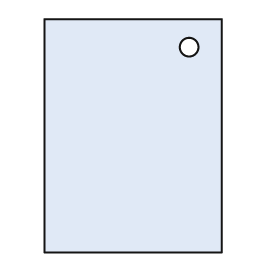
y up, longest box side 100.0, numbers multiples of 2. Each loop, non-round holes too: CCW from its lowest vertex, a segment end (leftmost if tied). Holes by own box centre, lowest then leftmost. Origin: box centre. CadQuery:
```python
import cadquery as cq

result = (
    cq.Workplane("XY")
    .moveTo(-38.0, -50.0)
    .lineTo(38.0, -50.0)
    .lineTo(38.0, 50.0)
    .lineTo(-38.0, 50.0)
    .close()
    .moveTo(24.0, 38.0)
    .circle(4.0)
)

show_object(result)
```